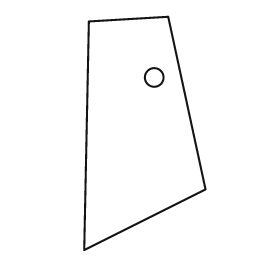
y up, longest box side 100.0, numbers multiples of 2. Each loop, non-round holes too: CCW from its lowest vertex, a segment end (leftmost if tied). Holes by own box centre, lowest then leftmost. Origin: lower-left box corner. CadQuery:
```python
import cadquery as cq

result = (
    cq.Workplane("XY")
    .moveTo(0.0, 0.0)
    .lineTo(52.0, 26.0)
    .lineTo(36.0, 100.0)
    .lineTo(2.0, 98.0)
    .close()
    .moveTo(30.0, 74.0)
    .circle(4.0)
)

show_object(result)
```